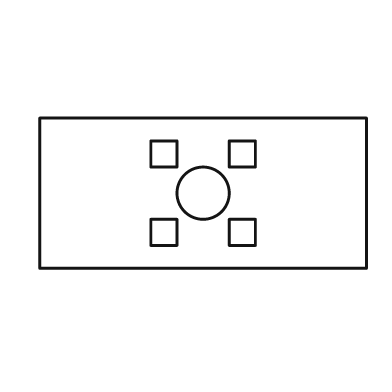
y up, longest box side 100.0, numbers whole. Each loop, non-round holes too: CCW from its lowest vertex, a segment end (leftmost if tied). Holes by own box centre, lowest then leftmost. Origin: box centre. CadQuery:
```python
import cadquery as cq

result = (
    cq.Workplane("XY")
    .moveTo(-50.0, -23.0)
    .lineTo(50.0, -23.0)
    .lineTo(50.0, 23.0)
    .lineTo(-50.0, 23.0)
    .close()
    .moveTo(-16.0, -16.0)
    .lineTo(-8.0, -16.0)
    .lineTo(-8.0, -8.0)
    .lineTo(-16.0, -8.0)
    .close()
    .moveTo(8.0, -16.0)
    .lineTo(16.0, -16.0)
    .lineTo(16.0, -8.0)
    .lineTo(8.0, -8.0)
    .close()
    .moveTo(0.0, 0.0)
    .circle(8.0)
    .moveTo(-16.0, 8.0)
    .lineTo(-8.0, 8.0)
    .lineTo(-8.0, 16.0)
    .lineTo(-16.0, 16.0)
    .close()
    .moveTo(8.0, 8.0)
    .lineTo(16.0, 8.0)
    .lineTo(16.0, 16.0)
    .lineTo(8.0, 16.0)
    .close()
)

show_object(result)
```